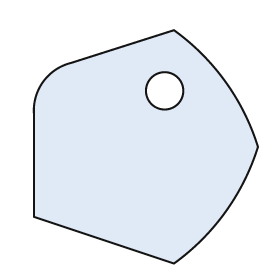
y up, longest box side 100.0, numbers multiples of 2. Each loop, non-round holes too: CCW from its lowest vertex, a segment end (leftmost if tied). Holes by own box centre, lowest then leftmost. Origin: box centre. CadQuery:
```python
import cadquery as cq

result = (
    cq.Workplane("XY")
    .moveTo(12.0, -50.0)
    .threePointArc((34.0, -28.0), (48.0, 0.0))
    .threePointArc((34.0, 28.0), (12.0, 50.0))
    .lineTo(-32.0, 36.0)
    .threePointArc((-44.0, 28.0), (-48.0, 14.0))
    .lineTo(-48.0, -30.0)
    .close()
    .moveTo(8.0, 24.0)
    .circle(8.0)
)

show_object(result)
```